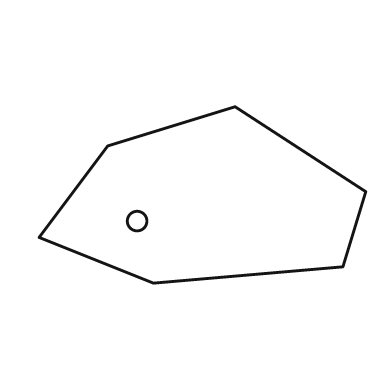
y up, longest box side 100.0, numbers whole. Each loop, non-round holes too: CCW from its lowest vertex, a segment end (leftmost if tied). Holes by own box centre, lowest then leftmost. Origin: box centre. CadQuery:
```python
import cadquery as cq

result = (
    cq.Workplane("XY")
    .moveTo(-15.0, -27.0)
    .lineTo(43.0, -22.0)
    .lineTo(50.0, 1.0)
    .lineTo(10.0, 27.0)
    .lineTo(-29.0, 15.0)
    .lineTo(-50.0, -13.0)
    .close()
    .moveTo(-20.0, -8.0)
    .circle(3.0)
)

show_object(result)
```